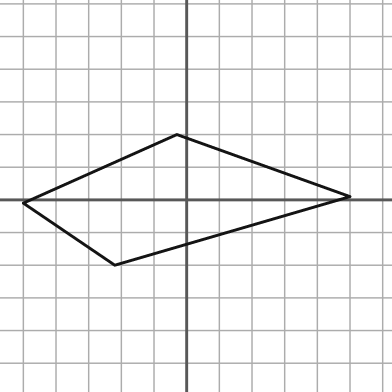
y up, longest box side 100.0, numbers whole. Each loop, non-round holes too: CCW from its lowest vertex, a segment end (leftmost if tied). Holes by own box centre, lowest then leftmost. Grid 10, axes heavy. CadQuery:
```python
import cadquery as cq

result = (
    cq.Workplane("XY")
    .moveTo(-22.0, -20.0)
    .lineTo(50.0, 1.0)
    .lineTo(-3.0, 20.0)
    .lineTo(-50.0, -1.0)
    .close()
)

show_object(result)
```